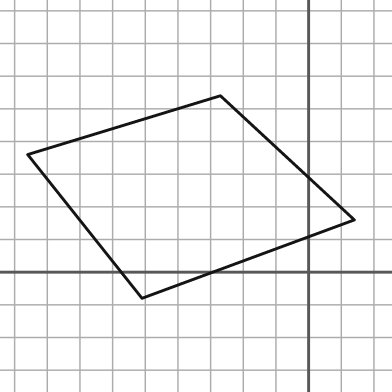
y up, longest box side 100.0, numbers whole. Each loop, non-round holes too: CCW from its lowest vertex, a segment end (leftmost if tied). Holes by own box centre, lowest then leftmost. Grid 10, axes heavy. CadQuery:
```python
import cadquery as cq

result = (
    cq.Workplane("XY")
    .moveTo(-51.0, -8.0)
    .lineTo(14.0, 16.0)
    .lineTo(-27.0, 54.0)
    .lineTo(-86.0, 36.0)
    .close()
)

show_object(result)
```